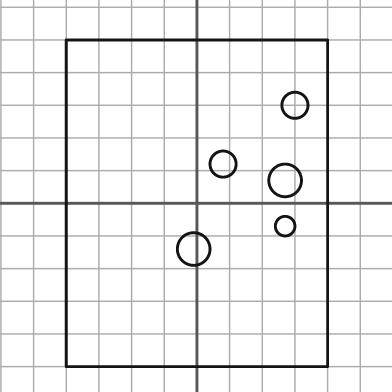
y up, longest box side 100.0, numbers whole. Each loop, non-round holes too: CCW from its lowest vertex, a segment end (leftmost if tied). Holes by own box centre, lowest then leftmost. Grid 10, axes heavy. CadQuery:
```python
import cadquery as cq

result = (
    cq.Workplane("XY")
    .moveTo(-40.0, -50.0)
    .lineTo(40.0, -50.0)
    .lineTo(40.0, 50.0)
    .lineTo(-40.0, 50.0)
    .close()
    .moveTo(-1.0, -14.0)
    .circle(5.0)
    .moveTo(27.0, -7.0)
    .circle(3.0)
    .moveTo(27.0, 7.0)
    .circle(5.0)
    .moveTo(8.0, 12.0)
    .circle(4.0)
    .moveTo(30.0, 30.0)
    .circle(4.0)
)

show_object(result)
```